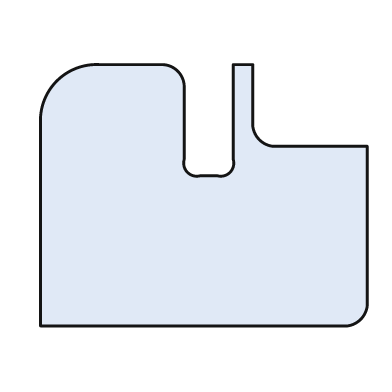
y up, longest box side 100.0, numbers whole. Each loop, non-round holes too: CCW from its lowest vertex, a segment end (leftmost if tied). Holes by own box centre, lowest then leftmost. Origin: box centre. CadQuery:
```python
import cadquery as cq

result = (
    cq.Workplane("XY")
    .moveTo(-50.0, -40.0)
    .lineTo(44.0, -40.0)
    .threePointArc((48.0, -38.0), (50.0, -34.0))
    .lineTo(50.0, 15.0)
    .lineTo(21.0, 15.0)
    .threePointArc((17.0, 17.0), (15.0, 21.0))
    .lineTo(15.0, 40.0)
    .lineTo(9.0, 40.0)
    .lineTo(9.0, 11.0)
    .threePointArc((8.0, 7.0), (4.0, 6.0))
    .lineTo(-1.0, 6.0)
    .threePointArc((-5.0, 7.0), (-6.0, 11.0))
    .lineTo(-6.0, 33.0)
    .threePointArc((-8.0, 38.0), (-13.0, 40.0))
    .lineTo(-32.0, 40.0)
    .threePointArc((-45.0, 35.0), (-50.0, 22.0))
    .close()
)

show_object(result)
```